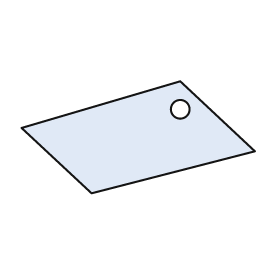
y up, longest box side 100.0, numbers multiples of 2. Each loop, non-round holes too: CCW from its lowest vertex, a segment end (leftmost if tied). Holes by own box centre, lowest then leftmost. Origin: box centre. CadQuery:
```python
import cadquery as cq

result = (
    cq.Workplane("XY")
    .moveTo(-20.0, -24.0)
    .lineTo(50.0, -6.0)
    .lineTo(18.0, 24.0)
    .lineTo(-50.0, 4.0)
    .close()
    .moveTo(18.0, 12.0)
    .circle(4.0)
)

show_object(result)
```